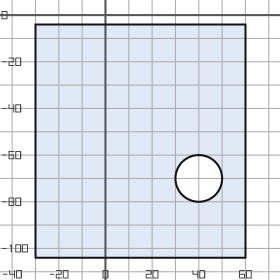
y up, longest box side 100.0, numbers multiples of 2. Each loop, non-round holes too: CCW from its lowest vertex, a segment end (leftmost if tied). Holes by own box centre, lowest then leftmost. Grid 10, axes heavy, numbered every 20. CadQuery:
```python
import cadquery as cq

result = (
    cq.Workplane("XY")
    .moveTo(-30.0, -104.0)
    .lineTo(60.0, -104.0)
    .lineTo(60.0, -4.0)
    .lineTo(-30.0, -4.0)
    .close()
    .moveTo(40.0, -70.0)
    .circle(10.0)
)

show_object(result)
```